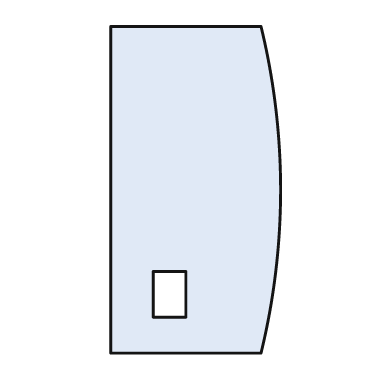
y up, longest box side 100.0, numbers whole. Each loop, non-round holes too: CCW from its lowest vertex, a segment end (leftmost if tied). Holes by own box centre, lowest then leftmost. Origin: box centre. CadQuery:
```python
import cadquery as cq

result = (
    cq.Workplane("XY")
    .moveTo(-26.0, -50.0)
    .lineTo(20.0, -50.0)
    .threePointArc((26.0, 0.0), (20.0, 50.0))
    .lineTo(-26.0, 50.0)
    .close()
    .moveTo(-13.0, -39.0)
    .lineTo(-3.0, -39.0)
    .lineTo(-3.0, -25.0)
    .lineTo(-13.0, -25.0)
    .close()
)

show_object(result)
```